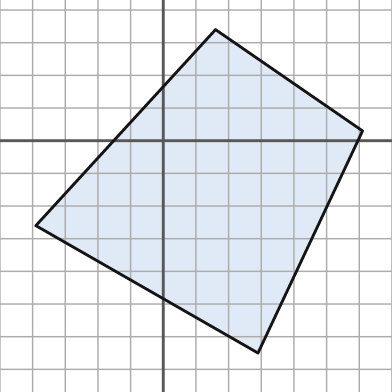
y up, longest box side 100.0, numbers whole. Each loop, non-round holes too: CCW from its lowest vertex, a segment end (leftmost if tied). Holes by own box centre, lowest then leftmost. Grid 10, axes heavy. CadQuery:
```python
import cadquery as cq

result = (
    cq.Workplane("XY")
    .moveTo(29.0, -65.0)
    .lineTo(61.0, 3.0)
    .lineTo(16.0, 34.0)
    .lineTo(-39.0, -26.0)
    .close()
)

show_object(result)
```